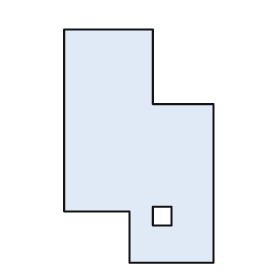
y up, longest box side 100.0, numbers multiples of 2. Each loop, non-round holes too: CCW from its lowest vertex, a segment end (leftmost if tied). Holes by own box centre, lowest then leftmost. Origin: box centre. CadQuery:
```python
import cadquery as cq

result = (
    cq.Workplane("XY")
    .moveTo(-4.0, -50.0)
    .lineTo(32.0, -50.0)
    .lineTo(32.0, 18.0)
    .lineTo(6.0, 18.0)
    .lineTo(6.0, 50.0)
    .lineTo(-32.0, 50.0)
    .lineTo(-32.0, -28.0)
    .lineTo(-4.0, -28.0)
    .close()
    .moveTo(6.0, -34.0)
    .lineTo(14.0, -34.0)
    .lineTo(14.0, -26.0)
    .lineTo(6.0, -26.0)
    .close()
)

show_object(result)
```